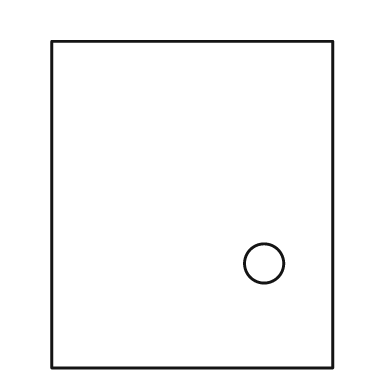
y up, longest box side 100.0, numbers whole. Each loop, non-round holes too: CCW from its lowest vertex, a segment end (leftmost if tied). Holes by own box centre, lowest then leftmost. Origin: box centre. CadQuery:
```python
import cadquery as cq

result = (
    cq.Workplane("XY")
    .moveTo(-43.0, -50.0)
    .lineTo(43.0, -50.0)
    .lineTo(43.0, 50.0)
    .lineTo(-43.0, 50.0)
    .close()
    .moveTo(22.0, -18.0)
    .circle(6.0)
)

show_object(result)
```